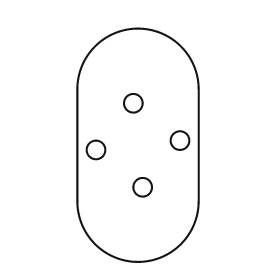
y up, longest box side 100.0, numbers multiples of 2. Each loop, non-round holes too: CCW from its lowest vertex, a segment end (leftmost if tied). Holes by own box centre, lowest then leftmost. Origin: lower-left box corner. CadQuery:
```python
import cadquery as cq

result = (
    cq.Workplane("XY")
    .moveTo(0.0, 26.0)
    .threePointArc((26.0, 0.0), (52.0, 26.0))
    .lineTo(52.0, 74.0)
    .threePointArc((26.0, 100.0), (0.0, 74.0))
    .close()
    .moveTo(28.0, 32.0)
    .circle(4.0)
    .moveTo(8.0, 48.0)
    .circle(4.0)
    .moveTo(44.0, 52.0)
    .circle(4.0)
    .moveTo(24.0, 68.0)
    .circle(4.0)
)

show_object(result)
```